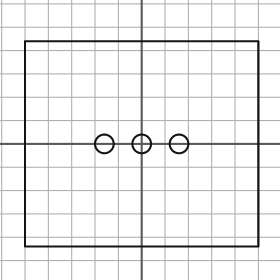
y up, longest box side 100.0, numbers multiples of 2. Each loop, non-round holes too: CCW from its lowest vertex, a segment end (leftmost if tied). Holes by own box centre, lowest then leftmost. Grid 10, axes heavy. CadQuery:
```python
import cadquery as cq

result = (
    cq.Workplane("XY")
    .moveTo(-50.0, -44.0)
    .lineTo(50.0, -44.0)
    .lineTo(50.0, 44.0)
    .lineTo(-50.0, 44.0)
    .close()
    .moveTo(-16.0, 0.0)
    .circle(4.0)
    .moveTo(0.0, 0.0)
    .circle(4.0)
    .moveTo(16.0, 0.0)
    .circle(4.0)
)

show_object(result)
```